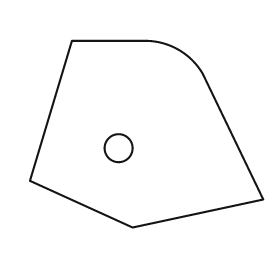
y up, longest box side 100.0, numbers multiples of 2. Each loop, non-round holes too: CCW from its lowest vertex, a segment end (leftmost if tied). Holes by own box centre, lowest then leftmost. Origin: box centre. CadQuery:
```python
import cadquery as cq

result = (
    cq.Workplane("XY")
    .moveTo(-6.0, -40.0)
    .lineTo(50.0, -28.0)
    .lineTo(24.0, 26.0)
    .threePointArc((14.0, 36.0), (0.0, 40.0))
    .lineTo(-32.0, 40.0)
    .lineTo(-50.0, -20.0)
    .close()
    .moveTo(-12.0, -6.0)
    .circle(6.0)
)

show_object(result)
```